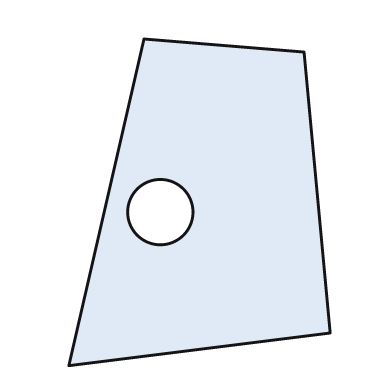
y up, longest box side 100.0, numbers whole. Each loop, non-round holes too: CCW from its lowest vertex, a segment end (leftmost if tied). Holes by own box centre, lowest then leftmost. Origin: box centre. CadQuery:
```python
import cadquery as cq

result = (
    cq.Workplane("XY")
    .moveTo(-40.0, -50.0)
    .lineTo(40.0, -40.0)
    .lineTo(32.0, 46.0)
    .lineTo(-17.0, 50.0)
    .close()
    .moveTo(-12.0, -3.0)
    .circle(10.0)
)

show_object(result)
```